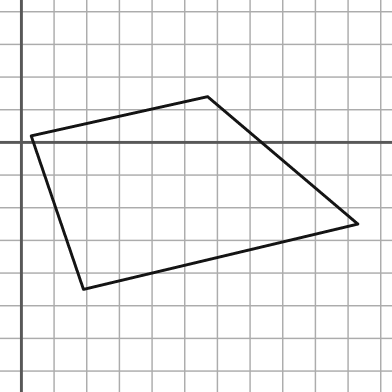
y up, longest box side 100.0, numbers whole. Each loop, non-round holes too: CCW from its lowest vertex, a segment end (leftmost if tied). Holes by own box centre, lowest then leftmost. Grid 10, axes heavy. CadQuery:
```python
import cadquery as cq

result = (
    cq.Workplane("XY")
    .moveTo(19.0, -45.0)
    .lineTo(103.0, -25.0)
    .lineTo(57.0, 14.0)
    .lineTo(3.0, 2.0)
    .close()
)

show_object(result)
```